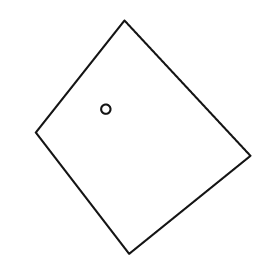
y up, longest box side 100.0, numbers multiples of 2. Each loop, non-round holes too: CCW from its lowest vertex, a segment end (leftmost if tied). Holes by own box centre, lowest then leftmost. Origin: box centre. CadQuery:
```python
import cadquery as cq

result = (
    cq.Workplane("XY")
    .moveTo(-6.0, -50.0)
    .lineTo(46.0, -8.0)
    .lineTo(-8.0, 50.0)
    .lineTo(-46.0, 2.0)
    .close()
    .moveTo(-16.0, 12.0)
    .circle(2.0)
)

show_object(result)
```